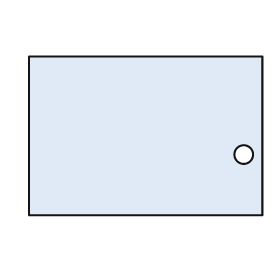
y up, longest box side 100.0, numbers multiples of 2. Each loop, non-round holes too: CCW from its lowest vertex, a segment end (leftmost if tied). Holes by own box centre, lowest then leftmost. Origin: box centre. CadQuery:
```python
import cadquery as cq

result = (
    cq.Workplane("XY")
    .moveTo(-50.0, -34.0)
    .lineTo(50.0, -34.0)
    .lineTo(50.0, 34.0)
    .lineTo(-50.0, 34.0)
    .close()
    .moveTo(42.0, -8.0)
    .circle(4.0)
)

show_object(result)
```